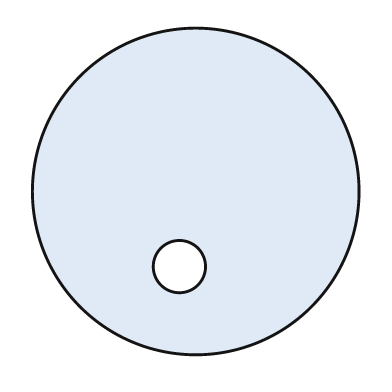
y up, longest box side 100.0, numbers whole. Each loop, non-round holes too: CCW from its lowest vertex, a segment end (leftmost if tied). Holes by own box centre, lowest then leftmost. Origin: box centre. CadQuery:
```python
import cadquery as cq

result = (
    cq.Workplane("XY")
    .moveTo(0.0, 0.0)
    .circle(50.0)
    .moveTo(-5.0, -23.0)
    .circle(8.0)
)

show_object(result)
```